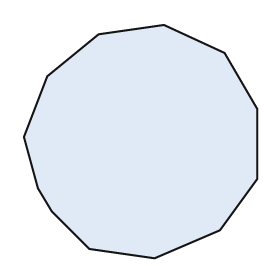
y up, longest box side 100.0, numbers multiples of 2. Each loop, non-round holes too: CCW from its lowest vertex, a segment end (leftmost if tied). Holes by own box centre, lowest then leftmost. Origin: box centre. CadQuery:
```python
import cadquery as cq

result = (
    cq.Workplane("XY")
    .moveTo(6.0, -50.0)
    .lineTo(34.0, -38.0)
    .lineTo(50.0, -16.0)
    .lineTo(50.0, 14.0)
    .lineTo(36.0, 38.0)
    .lineTo(10.0, 50.0)
    .lineTo(-18.0, 46.0)
    .lineTo(-40.0, 28.0)
    .lineTo(-50.0, 2.0)
    .lineTo(-44.0, -20.0)
    .lineTo(-38.0, -30.0)
    .lineTo(-22.0, -46.0)
    .close()
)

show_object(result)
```